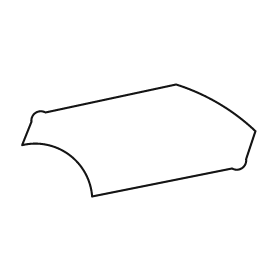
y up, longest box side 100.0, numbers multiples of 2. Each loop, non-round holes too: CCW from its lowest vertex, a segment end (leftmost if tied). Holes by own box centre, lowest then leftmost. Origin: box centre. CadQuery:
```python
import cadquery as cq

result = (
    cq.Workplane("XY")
    .moveTo(-20.0, -24.0)
    .lineTo(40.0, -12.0)
    .threePointArc((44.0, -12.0), (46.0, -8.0))
    .lineTo(50.0, 4.0)
    .threePointArc((34.0, 16.0), (16.0, 24.0))
    .lineTo(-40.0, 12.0)
    .threePointArc((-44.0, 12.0), (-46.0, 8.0))
    .lineTo(-50.0, -2.0)
    .threePointArc((-30.0, -6.0), (-20.0, -24.0))
    .close()
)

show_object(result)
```